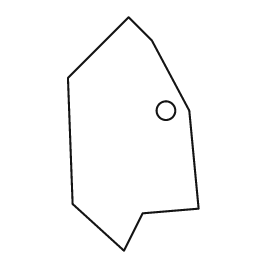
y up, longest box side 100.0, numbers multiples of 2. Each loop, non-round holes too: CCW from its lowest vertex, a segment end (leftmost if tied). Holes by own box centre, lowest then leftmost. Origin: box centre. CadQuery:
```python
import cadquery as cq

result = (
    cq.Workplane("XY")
    .moveTo(-4.0, -50.0)
    .lineTo(4.0, -34.0)
    .lineTo(28.0, -32.0)
    .lineTo(24.0, 10.0)
    .lineTo(8.0, 40.0)
    .lineTo(-2.0, 50.0)
    .lineTo(-28.0, 24.0)
    .lineTo(-26.0, -30.0)
    .close()
    .moveTo(14.0, 10.0)
    .circle(4.0)
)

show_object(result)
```